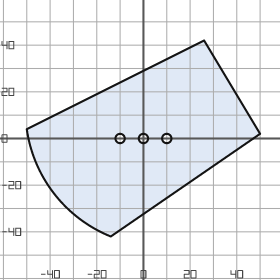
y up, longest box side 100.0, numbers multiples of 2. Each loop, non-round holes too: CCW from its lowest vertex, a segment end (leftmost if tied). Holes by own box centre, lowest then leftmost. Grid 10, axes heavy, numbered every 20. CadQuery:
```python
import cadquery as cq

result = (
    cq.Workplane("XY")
    .moveTo(-14.0, -42.0)
    .lineTo(50.0, 2.0)
    .lineTo(26.0, 42.0)
    .lineTo(-50.0, 4.0)
    .threePointArc((-38.0, -24.0), (-14.0, -42.0))
    .close()
    .moveTo(-10.0, 0.0)
    .circle(2.0)
    .moveTo(0.0, 0.0)
    .circle(2.0)
    .moveTo(10.0, 0.0)
    .circle(2.0)
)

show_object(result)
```